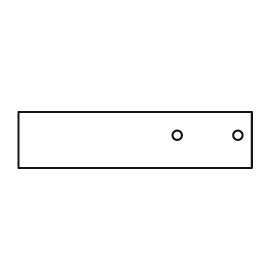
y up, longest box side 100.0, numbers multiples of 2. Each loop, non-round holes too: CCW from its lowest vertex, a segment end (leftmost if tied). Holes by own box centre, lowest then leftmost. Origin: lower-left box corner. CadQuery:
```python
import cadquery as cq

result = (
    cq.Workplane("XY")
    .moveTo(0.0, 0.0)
    .lineTo(100.0, 0.0)
    .lineTo(100.0, 24.0)
    .lineTo(0.0, 24.0)
    .close()
    .moveTo(68.0, 14.0)
    .circle(2.0)
    .moveTo(94.0, 14.0)
    .circle(2.0)
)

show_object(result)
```